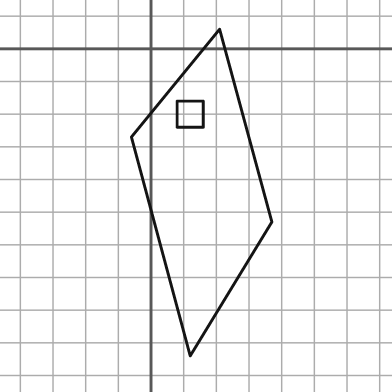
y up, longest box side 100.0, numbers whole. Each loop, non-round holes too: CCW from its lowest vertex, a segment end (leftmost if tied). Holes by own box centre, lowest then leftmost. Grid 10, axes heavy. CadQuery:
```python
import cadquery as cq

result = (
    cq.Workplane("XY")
    .moveTo(12.0, -94.0)
    .lineTo(37.0, -53.0)
    .lineTo(21.0, 6.0)
    .lineTo(-6.0, -27.0)
    .close()
    .moveTo(8.0, -24.0)
    .lineTo(16.0, -24.0)
    .lineTo(16.0, -16.0)
    .lineTo(8.0, -16.0)
    .close()
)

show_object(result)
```